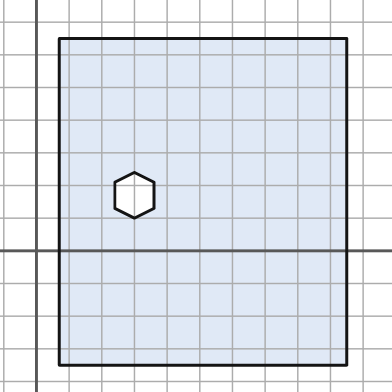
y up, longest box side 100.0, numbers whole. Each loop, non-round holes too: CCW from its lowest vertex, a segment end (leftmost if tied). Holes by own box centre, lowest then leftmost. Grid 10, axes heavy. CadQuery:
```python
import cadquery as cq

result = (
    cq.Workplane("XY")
    .moveTo(7.0, -35.0)
    .lineTo(95.0, -35.0)
    .lineTo(95.0, 65.0)
    .lineTo(7.0, 65.0)
    .close()
    .moveTo(30.0, 10.0)
    .lineTo(36.0, 13.0)
    .lineTo(36.0, 21.0)
    .lineTo(30.0, 24.0)
    .lineTo(24.0, 21.0)
    .lineTo(24.0, 13.0)
    .close()
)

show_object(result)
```